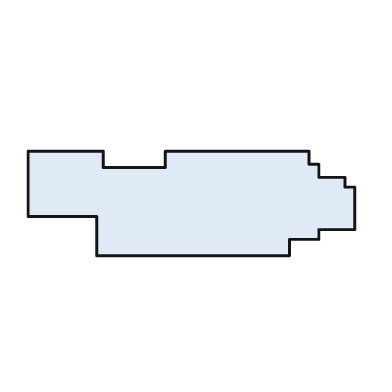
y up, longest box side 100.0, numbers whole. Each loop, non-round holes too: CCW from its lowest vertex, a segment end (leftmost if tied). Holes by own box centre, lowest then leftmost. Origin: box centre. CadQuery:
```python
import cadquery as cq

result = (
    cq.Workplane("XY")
    .moveTo(-29.0, -16.0)
    .lineTo(30.0, -16.0)
    .lineTo(30.0, -11.0)
    .lineTo(39.0, -11.0)
    .lineTo(39.0, -8.0)
    .lineTo(50.0, -8.0)
    .lineTo(50.0, 5.0)
    .lineTo(47.0, 5.0)
    .lineTo(47.0, 8.0)
    .lineTo(39.0, 8.0)
    .lineTo(39.0, 12.0)
    .lineTo(36.0, 12.0)
    .lineTo(36.0, 16.0)
    .lineTo(-8.0, 16.0)
    .lineTo(-8.0, 11.0)
    .lineTo(-27.0, 11.0)
    .lineTo(-27.0, 16.0)
    .lineTo(-50.0, 16.0)
    .lineTo(-50.0, -4.0)
    .lineTo(-29.0, -4.0)
    .close()
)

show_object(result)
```